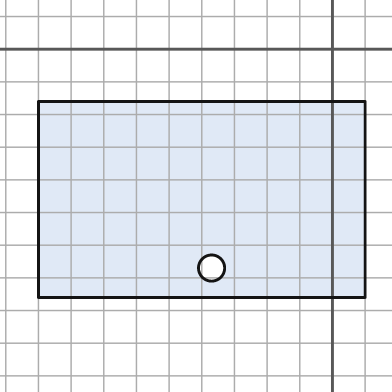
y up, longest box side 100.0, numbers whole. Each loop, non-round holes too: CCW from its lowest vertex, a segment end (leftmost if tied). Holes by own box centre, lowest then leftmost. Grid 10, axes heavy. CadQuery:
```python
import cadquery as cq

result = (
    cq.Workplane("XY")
    .moveTo(-90.0, -76.0)
    .lineTo(10.0, -76.0)
    .lineTo(10.0, -16.0)
    .lineTo(-90.0, -16.0)
    .close()
    .moveTo(-37.0, -67.0)
    .circle(4.0)
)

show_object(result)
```